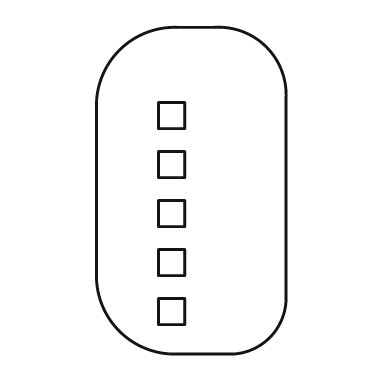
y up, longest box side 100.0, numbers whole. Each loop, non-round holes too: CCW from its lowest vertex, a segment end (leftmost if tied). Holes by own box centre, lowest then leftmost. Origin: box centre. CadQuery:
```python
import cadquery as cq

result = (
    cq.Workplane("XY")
    .moveTo(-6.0, -50.0)
    .lineTo(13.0, -50.0)
    .threePointArc((24.0, -45.0), (29.0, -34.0))
    .lineTo(29.0, 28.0)
    .threePointArc((23.0, 44.0), (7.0, 50.0))
    .lineTo(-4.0, 50.0)
    .threePointArc((-22.0, 43.0), (-29.0, 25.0))
    .lineTo(-29.0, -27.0)
    .threePointArc((-22.0, -43.0), (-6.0, -50.0))
    .close()
    .moveTo(-10.0, -41.0)
    .lineTo(-2.0, -41.0)
    .lineTo(-2.0, -33.0)
    .lineTo(-10.0, -33.0)
    .close()
    .moveTo(-10.0, -26.0)
    .lineTo(-2.0, -26.0)
    .lineTo(-2.0, -18.0)
    .lineTo(-10.0, -18.0)
    .close()
    .moveTo(-10.0, -11.0)
    .lineTo(-2.0, -11.0)
    .lineTo(-2.0, -3.0)
    .lineTo(-10.0, -3.0)
    .close()
    .moveTo(-10.0, 4.0)
    .lineTo(-2.0, 4.0)
    .lineTo(-2.0, 12.0)
    .lineTo(-10.0, 12.0)
    .close()
    .moveTo(-10.0, 19.0)
    .lineTo(-2.0, 19.0)
    .lineTo(-2.0, 27.0)
    .lineTo(-10.0, 27.0)
    .close()
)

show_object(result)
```